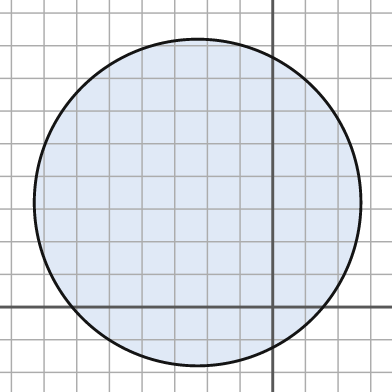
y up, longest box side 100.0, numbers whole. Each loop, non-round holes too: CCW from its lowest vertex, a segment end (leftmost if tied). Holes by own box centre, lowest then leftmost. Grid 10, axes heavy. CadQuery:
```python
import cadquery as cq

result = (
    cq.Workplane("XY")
    .moveTo(-23.0, 32.0)
    .circle(50.0)
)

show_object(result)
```